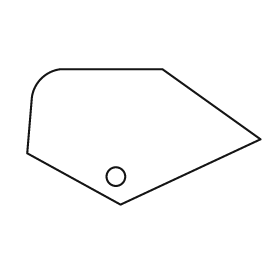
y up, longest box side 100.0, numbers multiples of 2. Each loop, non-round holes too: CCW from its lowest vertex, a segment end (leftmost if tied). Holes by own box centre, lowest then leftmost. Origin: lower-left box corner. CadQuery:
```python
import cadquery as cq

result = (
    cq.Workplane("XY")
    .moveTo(40.0, 0.0)
    .lineTo(100.0, 28.0)
    .lineTo(58.0, 58.0)
    .lineTo(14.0, 58.0)
    .threePointArc((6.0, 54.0), (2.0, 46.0))
    .lineTo(0.0, 22.0)
    .close()
    .moveTo(38.0, 12.0)
    .circle(4.0)
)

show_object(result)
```